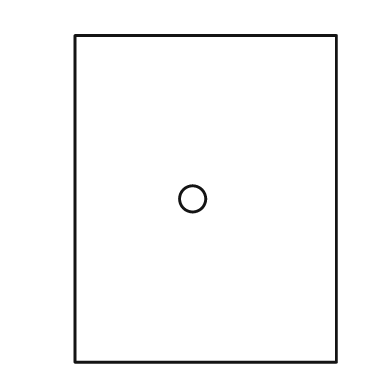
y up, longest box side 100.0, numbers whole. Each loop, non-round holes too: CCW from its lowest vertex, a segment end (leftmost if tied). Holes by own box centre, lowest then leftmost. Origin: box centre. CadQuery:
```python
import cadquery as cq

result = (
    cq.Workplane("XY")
    .moveTo(-40.0, -50.0)
    .lineTo(40.0, -50.0)
    .lineTo(40.0, 50.0)
    .lineTo(-40.0, 50.0)
    .close()
    .moveTo(-4.0, 0.0)
    .circle(4.0)
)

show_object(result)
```